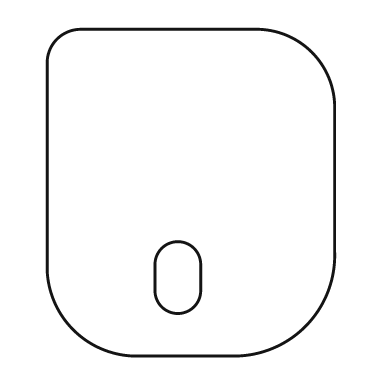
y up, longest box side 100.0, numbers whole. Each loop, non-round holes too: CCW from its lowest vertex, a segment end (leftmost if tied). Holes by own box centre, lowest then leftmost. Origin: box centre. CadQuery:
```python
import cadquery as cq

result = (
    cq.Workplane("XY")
    .moveTo(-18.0, -50.0)
    .lineTo(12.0, -50.0)
    .threePointArc((35.0, -41.0), (44.0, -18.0))
    .lineTo(44.0, 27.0)
    .threePointArc((37.0, 43.0), (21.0, 50.0))
    .lineTo(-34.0, 50.0)
    .threePointArc((-41.0, 47.0), (-44.0, 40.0))
    .lineTo(-44.0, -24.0)
    .threePointArc((-36.0, -42.0), (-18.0, -50.0))
    .close()
    .moveTo(-11.0, -30.0)
    .threePointArc((-4.0, -37.0), (3.0, -30.0))
    .lineTo(3.0, -22.0)
    .threePointArc((-4.0, -15.0), (-11.0, -22.0))
    .close()
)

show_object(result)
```